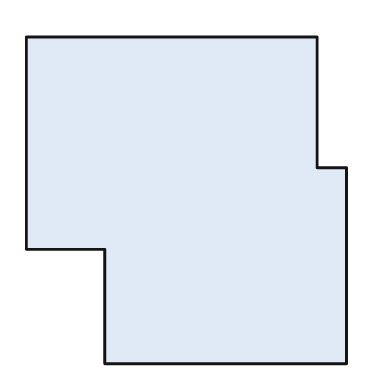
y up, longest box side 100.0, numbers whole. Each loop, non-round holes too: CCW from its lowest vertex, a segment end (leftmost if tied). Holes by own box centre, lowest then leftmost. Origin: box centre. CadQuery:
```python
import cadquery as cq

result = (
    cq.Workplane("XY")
    .moveTo(-25.0, -50.0)
    .lineTo(49.0, -50.0)
    .lineTo(49.0, 10.0)
    .lineTo(40.0, 10.0)
    .lineTo(40.0, 50.0)
    .lineTo(-49.0, 50.0)
    .lineTo(-49.0, -15.0)
    .lineTo(-25.0, -15.0)
    .close()
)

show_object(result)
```